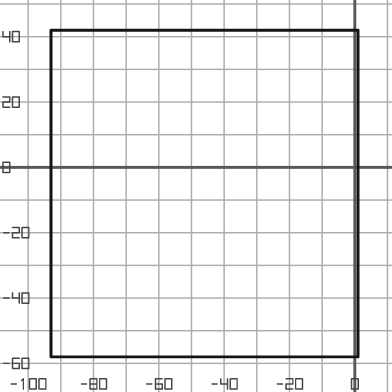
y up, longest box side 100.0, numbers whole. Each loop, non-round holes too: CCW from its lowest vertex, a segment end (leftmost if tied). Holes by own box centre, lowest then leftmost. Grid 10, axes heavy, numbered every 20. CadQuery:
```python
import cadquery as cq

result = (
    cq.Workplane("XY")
    .moveTo(-93.0, -58.0)
    .lineTo(1.0, -58.0)
    .lineTo(1.0, 42.0)
    .lineTo(-93.0, 42.0)
    .close()
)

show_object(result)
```